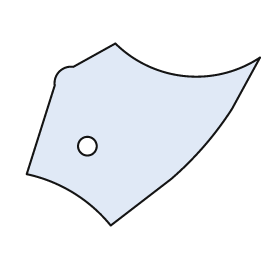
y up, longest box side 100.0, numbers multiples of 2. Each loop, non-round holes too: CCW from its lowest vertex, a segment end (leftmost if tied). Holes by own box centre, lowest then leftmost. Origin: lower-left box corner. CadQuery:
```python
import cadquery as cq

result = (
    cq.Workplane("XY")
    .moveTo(36.0, 0.0)
    .lineTo(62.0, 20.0)
    .threePointArc((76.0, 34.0), (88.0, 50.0))
    .lineTo(100.0, 72.0)
    .threePointArc((68.0, 64.0), (38.0, 78.0))
    .lineTo(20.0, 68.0)
    .threePointArc((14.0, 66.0), (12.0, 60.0))
    .lineTo(0.0, 22.0)
    .threePointArc((20.0, 14.0), (36.0, 0.0))
    .close()
    .moveTo(26.0, 34.0)
    .circle(4.0)
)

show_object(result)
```